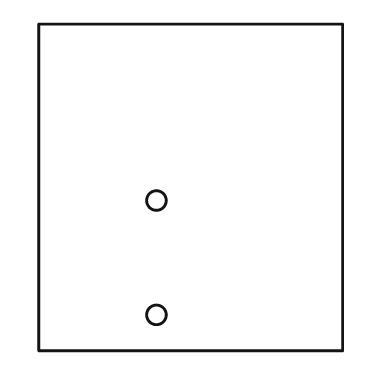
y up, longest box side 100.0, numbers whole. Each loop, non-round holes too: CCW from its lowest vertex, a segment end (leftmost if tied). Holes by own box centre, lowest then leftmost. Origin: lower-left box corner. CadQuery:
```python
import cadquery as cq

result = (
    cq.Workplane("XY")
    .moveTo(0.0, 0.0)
    .lineTo(93.0, 0.0)
    .lineTo(93.0, 100.0)
    .lineTo(0.0, 100.0)
    .close()
    .moveTo(36.0, 11.0)
    .circle(3.0)
    .moveTo(36.0, 46.0)
    .circle(3.0)
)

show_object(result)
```